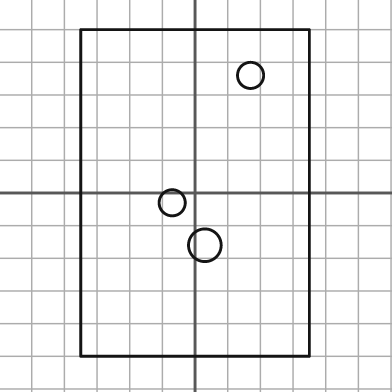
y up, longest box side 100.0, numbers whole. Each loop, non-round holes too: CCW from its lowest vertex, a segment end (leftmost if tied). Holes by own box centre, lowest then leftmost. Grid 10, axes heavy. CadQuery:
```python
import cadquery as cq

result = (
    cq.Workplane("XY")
    .moveTo(-35.0, -50.0)
    .lineTo(35.0, -50.0)
    .lineTo(35.0, 50.0)
    .lineTo(-35.0, 50.0)
    .close()
    .moveTo(3.0, -16.0)
    .circle(5.0)
    .moveTo(-7.0, -3.0)
    .circle(4.0)
    .moveTo(17.0, 36.0)
    .circle(4.0)
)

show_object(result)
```